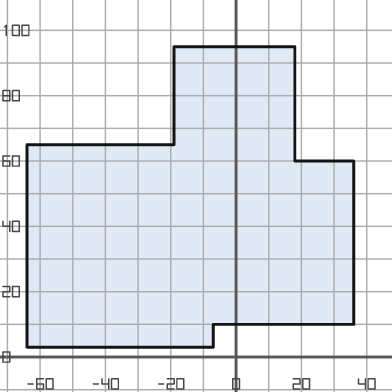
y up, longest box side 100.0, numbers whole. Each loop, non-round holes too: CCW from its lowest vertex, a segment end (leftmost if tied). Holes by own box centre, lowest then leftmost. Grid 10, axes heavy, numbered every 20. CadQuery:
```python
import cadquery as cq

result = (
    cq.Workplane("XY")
    .moveTo(-64.0, 3.0)
    .lineTo(-7.0, 3.0)
    .lineTo(-7.0, 10.0)
    .lineTo(36.0, 10.0)
    .lineTo(36.0, 60.0)
    .lineTo(18.0, 60.0)
    .lineTo(18.0, 95.0)
    .lineTo(-19.0, 95.0)
    .lineTo(-19.0, 65.0)
    .lineTo(-64.0, 65.0)
    .close()
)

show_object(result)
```